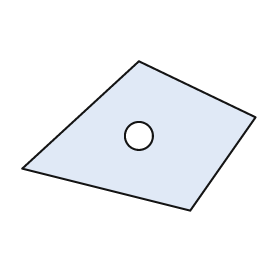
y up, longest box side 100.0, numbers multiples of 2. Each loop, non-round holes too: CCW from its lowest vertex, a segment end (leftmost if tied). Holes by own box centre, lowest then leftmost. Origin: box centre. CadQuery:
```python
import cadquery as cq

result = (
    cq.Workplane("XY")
    .moveTo(22.0, -32.0)
    .lineTo(50.0, 8.0)
    .lineTo(0.0, 32.0)
    .lineTo(-50.0, -14.0)
    .close()
    .moveTo(0.0, 0.0)
    .circle(6.0)
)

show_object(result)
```